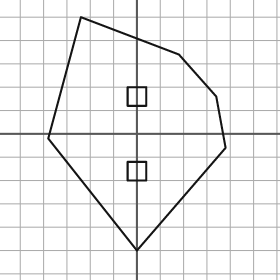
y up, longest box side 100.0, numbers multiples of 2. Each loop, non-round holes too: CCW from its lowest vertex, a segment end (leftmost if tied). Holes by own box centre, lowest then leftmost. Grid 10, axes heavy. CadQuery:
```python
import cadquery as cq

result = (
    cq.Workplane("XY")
    .moveTo(0.0, -50.0)
    .lineTo(38.0, -6.0)
    .lineTo(34.0, 16.0)
    .lineTo(18.0, 34.0)
    .lineTo(-24.0, 50.0)
    .lineTo(-38.0, -2.0)
    .close()
    .moveTo(-4.0, -20.0)
    .lineTo(4.0, -20.0)
    .lineTo(4.0, -12.0)
    .lineTo(-4.0, -12.0)
    .close()
    .moveTo(-4.0, 12.0)
    .lineTo(4.0, 12.0)
    .lineTo(4.0, 20.0)
    .lineTo(-4.0, 20.0)
    .close()
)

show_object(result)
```